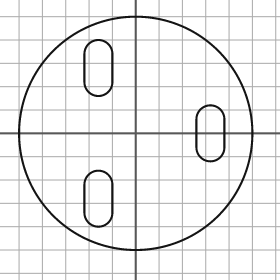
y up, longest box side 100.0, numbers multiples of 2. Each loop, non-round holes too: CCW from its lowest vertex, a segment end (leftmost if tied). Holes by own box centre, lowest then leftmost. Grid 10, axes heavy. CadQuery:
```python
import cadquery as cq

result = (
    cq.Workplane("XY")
    .moveTo(0.0, 0.0)
    .circle(50.0)
    .moveTo(-22.0, -34.0)
    .threePointArc((-16.0, -40.0), (-10.0, -34.0))
    .lineTo(-10.0, -22.0)
    .threePointArc((-16.0, -16.0), (-22.0, -22.0))
    .close()
    .moveTo(26.0, -6.0)
    .threePointArc((32.0, -12.0), (38.0, -6.0))
    .lineTo(38.0, 6.0)
    .threePointArc((32.0, 12.0), (26.0, 6.0))
    .close()
    .moveTo(-22.0, 22.0)
    .threePointArc((-16.0, 16.0), (-10.0, 22.0))
    .lineTo(-10.0, 34.0)
    .threePointArc((-16.0, 40.0), (-22.0, 34.0))
    .close()
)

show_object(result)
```